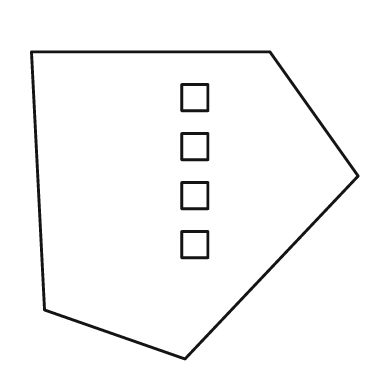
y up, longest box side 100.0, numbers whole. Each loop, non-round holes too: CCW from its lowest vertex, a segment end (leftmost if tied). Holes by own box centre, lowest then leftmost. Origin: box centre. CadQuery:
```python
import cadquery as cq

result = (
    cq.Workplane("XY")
    .moveTo(-3.0, -47.0)
    .lineTo(50.0, 9.0)
    .lineTo(23.0, 47.0)
    .lineTo(-50.0, 47.0)
    .lineTo(-46.0, -32.0)
    .close()
    .moveTo(-4.0, -16.0)
    .lineTo(4.0, -16.0)
    .lineTo(4.0, -8.0)
    .lineTo(-4.0, -8.0)
    .close()
    .moveTo(-4.0, -1.0)
    .lineTo(4.0, -1.0)
    .lineTo(4.0, 7.0)
    .lineTo(-4.0, 7.0)
    .close()
    .moveTo(-4.0, 14.0)
    .lineTo(4.0, 14.0)
    .lineTo(4.0, 22.0)
    .lineTo(-4.0, 22.0)
    .close()
    .moveTo(-4.0, 29.0)
    .lineTo(4.0, 29.0)
    .lineTo(4.0, 37.0)
    .lineTo(-4.0, 37.0)
    .close()
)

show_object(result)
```